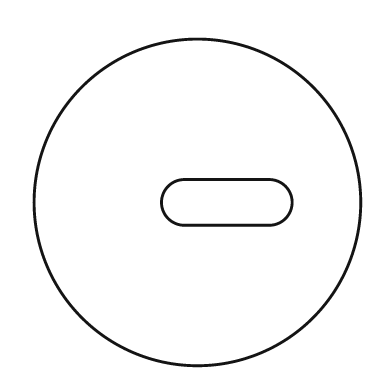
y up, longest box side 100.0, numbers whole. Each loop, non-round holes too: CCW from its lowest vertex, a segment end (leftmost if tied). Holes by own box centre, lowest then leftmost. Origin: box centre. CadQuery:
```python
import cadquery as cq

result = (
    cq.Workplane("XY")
    .moveTo(0.0, 0.0)
    .circle(50.0)
    .moveTo(-4.0, -7.0)
    .lineTo(22.0, -7.0)
    .threePointArc((29.0, 0.0), (22.0, 7.0))
    .lineTo(-4.0, 7.0)
    .threePointArc((-11.0, 0.0), (-4.0, -7.0))
    .close()
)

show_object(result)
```